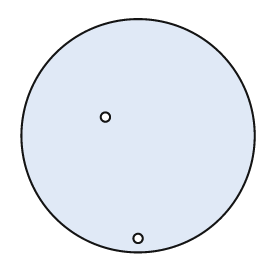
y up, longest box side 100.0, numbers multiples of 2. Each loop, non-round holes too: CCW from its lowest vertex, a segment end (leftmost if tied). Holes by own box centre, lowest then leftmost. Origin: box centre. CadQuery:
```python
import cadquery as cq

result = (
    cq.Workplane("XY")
    .moveTo(0.0, 0.0)
    .circle(50.0)
    .moveTo(0.0, -44.0)
    .circle(2.0)
    .moveTo(-14.0, 8.0)
    .circle(2.0)
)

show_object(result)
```